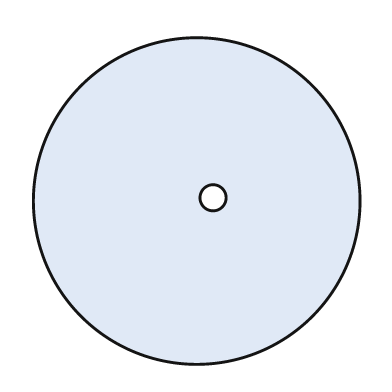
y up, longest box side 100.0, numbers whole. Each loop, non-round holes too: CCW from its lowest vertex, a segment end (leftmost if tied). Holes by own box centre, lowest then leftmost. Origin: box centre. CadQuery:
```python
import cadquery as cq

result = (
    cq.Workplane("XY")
    .moveTo(0.0, 0.0)
    .circle(50.0)
    .moveTo(5.0, 1.0)
    .circle(4.0)
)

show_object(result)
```